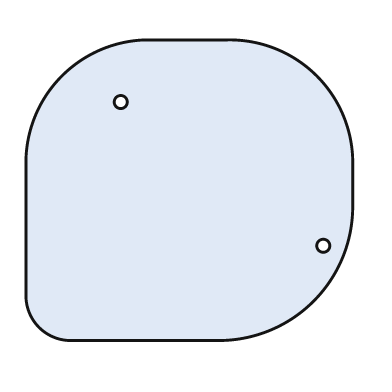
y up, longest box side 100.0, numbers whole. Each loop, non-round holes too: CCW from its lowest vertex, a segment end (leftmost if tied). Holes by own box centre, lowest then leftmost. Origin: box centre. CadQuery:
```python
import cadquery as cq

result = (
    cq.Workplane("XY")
    .moveTo(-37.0, -46.0)
    .lineTo(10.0, -46.0)
    .threePointArc((38.0, -34.0), (50.0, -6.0))
    .lineTo(50.0, 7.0)
    .threePointArc((39.0, 35.0), (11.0, 46.0))
    .lineTo(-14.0, 46.0)
    .threePointArc((-39.0, 35.0), (-50.0, 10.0))
    .lineTo(-50.0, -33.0)
    .threePointArc((-46.0, -42.0), (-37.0, -46.0))
    .close()
    .moveTo(41.0, -17.0)
    .circle(2.0)
    .moveTo(-21.0, 27.0)
    .circle(2.0)
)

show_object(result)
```